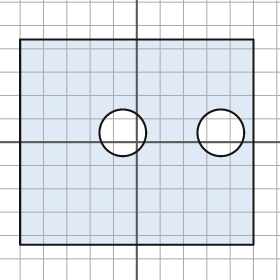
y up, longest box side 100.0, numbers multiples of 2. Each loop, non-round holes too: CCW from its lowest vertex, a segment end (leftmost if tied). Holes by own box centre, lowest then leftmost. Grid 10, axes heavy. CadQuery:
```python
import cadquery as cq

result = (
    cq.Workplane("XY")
    .moveTo(-50.0, -44.0)
    .lineTo(50.0, -44.0)
    .lineTo(50.0, 44.0)
    .lineTo(-50.0, 44.0)
    .close()
    .moveTo(-6.0, 4.0)
    .circle(10.0)
    .moveTo(36.0, 4.0)
    .circle(10.0)
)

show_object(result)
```